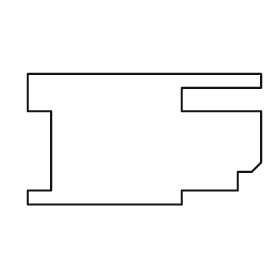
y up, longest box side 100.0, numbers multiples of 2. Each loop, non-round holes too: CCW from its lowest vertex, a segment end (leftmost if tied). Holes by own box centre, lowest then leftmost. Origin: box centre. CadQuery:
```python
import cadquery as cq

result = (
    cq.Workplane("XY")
    .moveTo(-50.0, -28.0)
    .lineTo(16.0, -28.0)
    .lineTo(16.0, -22.0)
    .lineTo(40.0, -22.0)
    .lineTo(40.0, -14.0)
    .lineTo(46.0, -14.0)
    .lineTo(50.0, -10.0)
    .lineTo(50.0, 12.0)
    .lineTo(16.0, 12.0)
    .lineTo(16.0, 22.0)
    .lineTo(50.0, 22.0)
    .lineTo(50.0, 28.0)
    .lineTo(-50.0, 28.0)
    .lineTo(-50.0, 12.0)
    .lineTo(-40.0, 12.0)
    .lineTo(-40.0, -22.0)
    .lineTo(-50.0, -22.0)
    .close()
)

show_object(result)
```